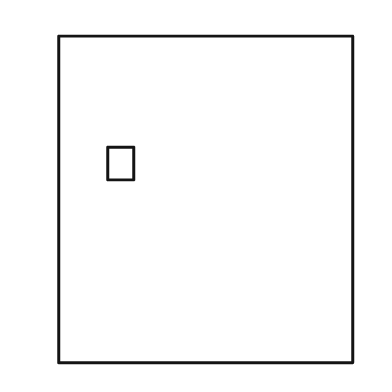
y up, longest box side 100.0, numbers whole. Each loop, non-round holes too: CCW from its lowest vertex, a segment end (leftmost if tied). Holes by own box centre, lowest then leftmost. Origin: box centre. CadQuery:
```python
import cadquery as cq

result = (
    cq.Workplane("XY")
    .moveTo(-45.0, -50.0)
    .lineTo(45.0, -50.0)
    .lineTo(45.0, 50.0)
    .lineTo(-45.0, 50.0)
    .close()
    .moveTo(-30.0, 6.0)
    .lineTo(-22.0, 6.0)
    .lineTo(-22.0, 16.0)
    .lineTo(-30.0, 16.0)
    .close()
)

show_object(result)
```